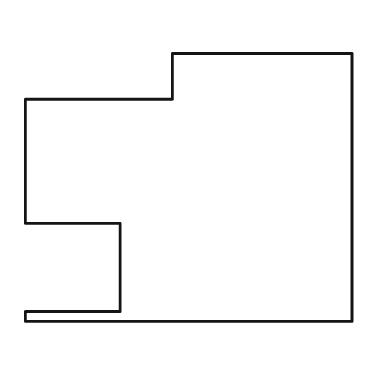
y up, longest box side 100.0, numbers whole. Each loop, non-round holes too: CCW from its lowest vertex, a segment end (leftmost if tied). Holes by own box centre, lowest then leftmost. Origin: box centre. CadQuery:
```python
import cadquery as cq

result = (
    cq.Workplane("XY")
    .moveTo(-50.0, -41.0)
    .lineTo(50.0, -41.0)
    .lineTo(50.0, 41.0)
    .lineTo(-5.0, 41.0)
    .lineTo(-5.0, 27.0)
    .lineTo(-50.0, 27.0)
    .lineTo(-50.0, -11.0)
    .lineTo(-21.0, -11.0)
    .lineTo(-21.0, -38.0)
    .lineTo(-50.0, -38.0)
    .close()
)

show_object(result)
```